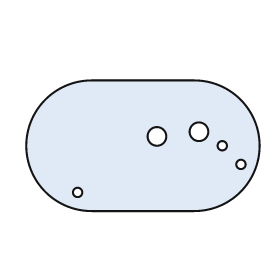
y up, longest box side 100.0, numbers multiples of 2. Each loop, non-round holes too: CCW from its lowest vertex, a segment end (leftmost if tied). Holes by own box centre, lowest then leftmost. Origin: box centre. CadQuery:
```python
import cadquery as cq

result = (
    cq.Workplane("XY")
    .moveTo(-22.0, -28.0)
    .lineTo(22.0, -28.0)
    .threePointArc((50.0, 0.0), (22.0, 28.0))
    .lineTo(-22.0, 28.0)
    .threePointArc((-50.0, 0.0), (-22.0, -28.0))
    .close()
    .moveTo(-28.0, -20.0)
    .circle(2.0)
    .moveTo(42.0, -8.0)
    .circle(2.0)
    .moveTo(34.0, 0.0)
    .circle(2.0)
    .moveTo(6.0, 4.0)
    .circle(4.0)
    .moveTo(24.0, 6.0)
    .circle(4.0)
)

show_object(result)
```